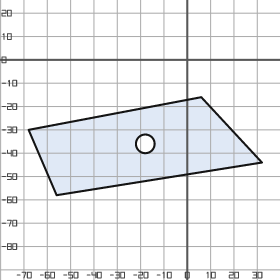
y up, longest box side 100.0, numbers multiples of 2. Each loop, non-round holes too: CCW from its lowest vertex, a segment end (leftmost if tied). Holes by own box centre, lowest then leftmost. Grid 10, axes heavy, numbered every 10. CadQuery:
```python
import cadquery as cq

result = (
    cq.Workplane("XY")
    .moveTo(-56.0, -58.0)
    .lineTo(32.0, -44.0)
    .lineTo(6.0, -16.0)
    .lineTo(-68.0, -30.0)
    .close()
    .moveTo(-18.0, -36.0)
    .circle(4.0)
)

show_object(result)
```